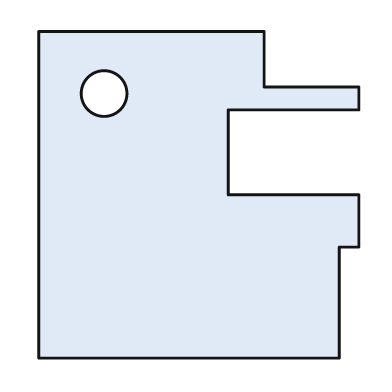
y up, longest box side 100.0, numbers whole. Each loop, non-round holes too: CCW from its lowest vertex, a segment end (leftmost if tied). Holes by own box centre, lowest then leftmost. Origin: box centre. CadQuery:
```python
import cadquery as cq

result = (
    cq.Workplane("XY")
    .moveTo(-49.0, -50.0)
    .lineTo(43.0, -50.0)
    .lineTo(43.0, -16.0)
    .lineTo(49.0, -16.0)
    .lineTo(49.0, 0.0)
    .lineTo(9.0, 0.0)
    .lineTo(9.0, 26.0)
    .lineTo(49.0, 26.0)
    .lineTo(49.0, 33.0)
    .lineTo(20.0, 33.0)
    .lineTo(20.0, 50.0)
    .lineTo(-49.0, 50.0)
    .close()
    .moveTo(-29.0, 31.0)
    .circle(7.0)
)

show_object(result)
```